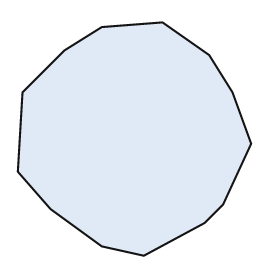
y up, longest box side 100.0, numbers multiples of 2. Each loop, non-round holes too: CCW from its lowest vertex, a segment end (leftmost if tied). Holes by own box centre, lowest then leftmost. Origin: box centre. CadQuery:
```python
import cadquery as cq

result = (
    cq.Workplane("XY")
    .moveTo(4.0, -50.0)
    .lineTo(30.0, -36.0)
    .lineTo(38.0, -28.0)
    .lineTo(50.0, -2.0)
    .lineTo(42.0, 20.0)
    .lineTo(32.0, 36.0)
    .lineTo(12.0, 50.0)
    .lineTo(-14.0, 48.0)
    .lineTo(-30.0, 38.0)
    .lineTo(-48.0, 20.0)
    .lineTo(-50.0, -14.0)
    .lineTo(-36.0, -30.0)
    .lineTo(-14.0, -46.0)
    .close()
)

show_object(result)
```